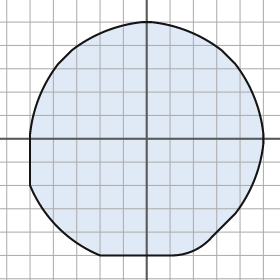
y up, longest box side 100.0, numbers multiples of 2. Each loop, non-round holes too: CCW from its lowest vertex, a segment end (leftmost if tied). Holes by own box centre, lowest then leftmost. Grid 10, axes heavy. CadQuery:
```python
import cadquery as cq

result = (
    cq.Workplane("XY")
    .moveTo(-20.0, -50.0)
    .lineTo(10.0, -50.0)
    .threePointArc((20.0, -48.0), (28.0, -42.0))
    .lineTo(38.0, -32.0)
    .threePointArc((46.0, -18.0), (50.0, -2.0))
    .lineTo(50.0, 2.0)
    .threePointArc((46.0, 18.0), (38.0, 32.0))
    .lineTo(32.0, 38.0)
    .threePointArc((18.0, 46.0), (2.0, 50.0))
    .lineTo(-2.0, 50.0)
    .threePointArc((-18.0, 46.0), (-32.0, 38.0))
    .lineTo(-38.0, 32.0)
    .threePointArc((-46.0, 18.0), (-50.0, 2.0))
    .lineTo(-50.0, -20.0)
    .threePointArc((-38.0, -38.0), (-20.0, -50.0))
    .close()
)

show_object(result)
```